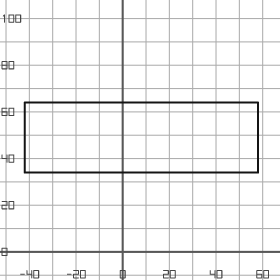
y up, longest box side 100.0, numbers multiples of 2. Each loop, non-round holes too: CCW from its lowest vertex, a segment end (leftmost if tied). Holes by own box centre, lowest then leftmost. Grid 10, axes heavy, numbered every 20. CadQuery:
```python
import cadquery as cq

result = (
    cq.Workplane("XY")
    .moveTo(-42.0, 34.0)
    .lineTo(58.0, 34.0)
    .lineTo(58.0, 64.0)
    .lineTo(-42.0, 64.0)
    .close()
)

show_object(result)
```